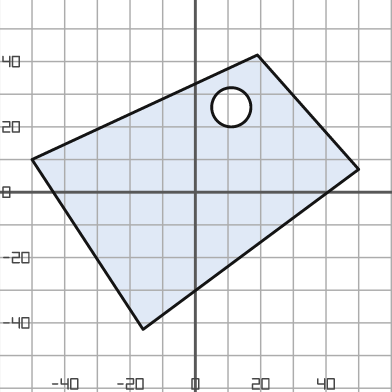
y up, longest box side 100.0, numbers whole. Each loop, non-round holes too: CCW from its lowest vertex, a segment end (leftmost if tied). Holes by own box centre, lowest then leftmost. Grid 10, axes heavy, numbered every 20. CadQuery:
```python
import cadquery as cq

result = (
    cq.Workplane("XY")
    .moveTo(-16.0, -42.0)
    .lineTo(50.0, 7.0)
    .lineTo(19.0, 42.0)
    .lineTo(-50.0, 10.0)
    .close()
    .moveTo(11.0, 26.0)
    .circle(6.0)
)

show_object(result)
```